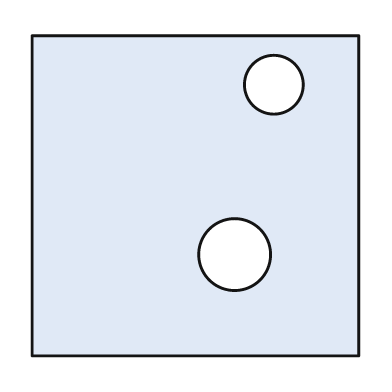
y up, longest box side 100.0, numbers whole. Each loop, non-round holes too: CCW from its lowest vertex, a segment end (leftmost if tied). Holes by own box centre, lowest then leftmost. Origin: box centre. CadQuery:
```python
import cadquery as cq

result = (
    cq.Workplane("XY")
    .moveTo(-50.0, -49.0)
    .lineTo(50.0, -49.0)
    .lineTo(50.0, 49.0)
    .lineTo(-50.0, 49.0)
    .close()
    .moveTo(12.0, -18.0)
    .circle(11.0)
    .moveTo(24.0, 34.0)
    .circle(9.0)
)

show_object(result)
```